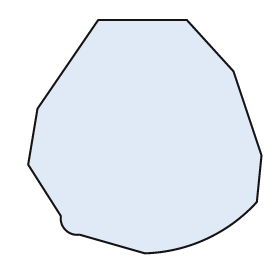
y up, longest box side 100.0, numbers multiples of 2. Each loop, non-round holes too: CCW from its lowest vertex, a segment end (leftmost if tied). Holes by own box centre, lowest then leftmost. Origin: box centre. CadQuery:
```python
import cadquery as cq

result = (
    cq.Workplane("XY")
    .moveTo(0.0, -50.0)
    .threePointArc((26.0, -44.0), (48.0, -28.0))
    .lineTo(50.0, -8.0)
    .lineTo(38.0, 28.0)
    .lineTo(18.0, 50.0)
    .lineTo(-20.0, 50.0)
    .lineTo(-46.0, 12.0)
    .lineTo(-50.0, -12.0)
    .lineTo(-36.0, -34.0)
    .threePointArc((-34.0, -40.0), (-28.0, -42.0))
    .close()
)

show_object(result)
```